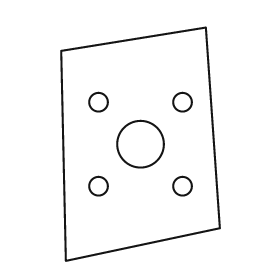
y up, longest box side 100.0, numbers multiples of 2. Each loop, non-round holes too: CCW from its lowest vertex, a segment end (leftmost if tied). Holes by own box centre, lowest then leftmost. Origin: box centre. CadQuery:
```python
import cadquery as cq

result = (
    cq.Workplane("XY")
    .moveTo(-32.0, -50.0)
    .lineTo(34.0, -36.0)
    .lineTo(28.0, 50.0)
    .lineTo(-34.0, 40.0)
    .close()
    .moveTo(-18.0, -18.0)
    .circle(4.0)
    .moveTo(18.0, -18.0)
    .circle(4.0)
    .moveTo(0.0, 0.0)
    .circle(10.0)
    .moveTo(-18.0, 18.0)
    .circle(4.0)
    .moveTo(18.0, 18.0)
    .circle(4.0)
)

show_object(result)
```